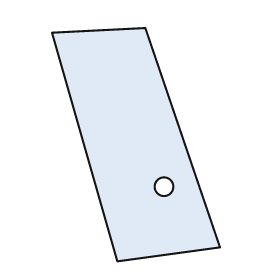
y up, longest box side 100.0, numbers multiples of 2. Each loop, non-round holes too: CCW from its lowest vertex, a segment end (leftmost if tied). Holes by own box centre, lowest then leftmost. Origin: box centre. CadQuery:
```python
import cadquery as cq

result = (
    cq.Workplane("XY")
    .moveTo(-8.0, -50.0)
    .lineTo(36.0, -44.0)
    .lineTo(4.0, 50.0)
    .lineTo(-36.0, 48.0)
    .close()
    .moveTo(12.0, -18.0)
    .circle(4.0)
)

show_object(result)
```